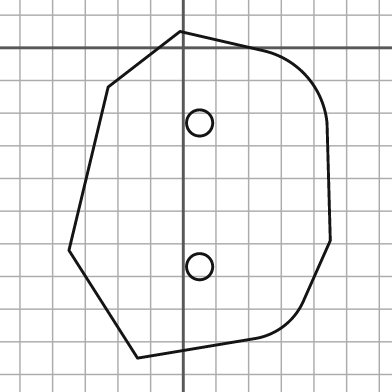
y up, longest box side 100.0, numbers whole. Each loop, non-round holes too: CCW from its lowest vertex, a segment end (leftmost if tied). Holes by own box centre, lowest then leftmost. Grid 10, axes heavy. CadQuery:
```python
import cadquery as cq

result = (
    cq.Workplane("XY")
    .moveTo(-14.0, -95.0)
    .lineTo(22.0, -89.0)
    .threePointArc((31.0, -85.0), (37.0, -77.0))
    .lineTo(45.0, -59.0)
    .lineTo(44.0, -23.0)
    .threePointArc((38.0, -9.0), (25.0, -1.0))
    .lineTo(-1.0, 5.0)
    .lineTo(-23.0, -12.0)
    .lineTo(-35.0, -62.0)
    .close()
    .moveTo(5.0, -67.0)
    .circle(4.0)
    .moveTo(5.0, -23.0)
    .circle(4.0)
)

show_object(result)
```